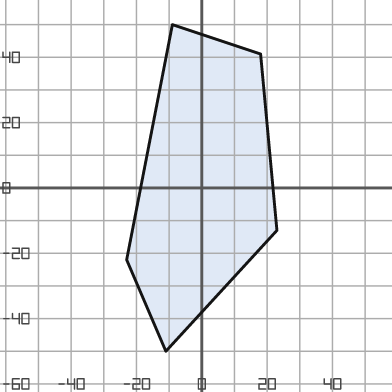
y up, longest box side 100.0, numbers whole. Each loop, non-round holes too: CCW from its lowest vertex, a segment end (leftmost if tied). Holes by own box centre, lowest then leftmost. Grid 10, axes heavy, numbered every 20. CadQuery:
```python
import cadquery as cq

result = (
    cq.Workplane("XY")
    .moveTo(-11.0, -50.0)
    .lineTo(23.0, -13.0)
    .lineTo(18.0, 41.0)
    .lineTo(-9.0, 50.0)
    .lineTo(-23.0, -22.0)
    .close()
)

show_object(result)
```